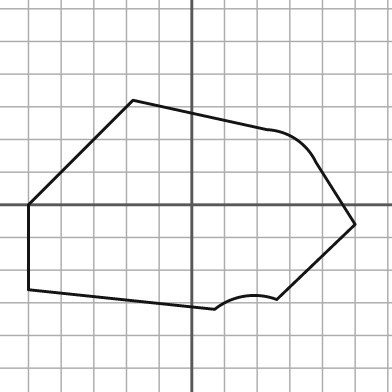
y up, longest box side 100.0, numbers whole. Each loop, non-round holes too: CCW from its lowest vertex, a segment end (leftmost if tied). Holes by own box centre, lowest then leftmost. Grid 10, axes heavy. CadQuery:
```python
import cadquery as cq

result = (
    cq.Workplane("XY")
    .moveTo(7.0, -32.0)
    .threePointArc((16.0, -28.0), (26.0, -29.0))
    .lineTo(50.0, -6.0)
    .lineTo(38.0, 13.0)
    .threePointArc((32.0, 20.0), (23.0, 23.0))
    .lineTo(-18.0, 32.0)
    .lineTo(-50.0, 0.0)
    .lineTo(-50.0, -26.0)
    .close()
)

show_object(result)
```